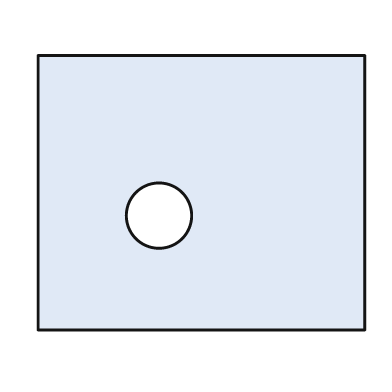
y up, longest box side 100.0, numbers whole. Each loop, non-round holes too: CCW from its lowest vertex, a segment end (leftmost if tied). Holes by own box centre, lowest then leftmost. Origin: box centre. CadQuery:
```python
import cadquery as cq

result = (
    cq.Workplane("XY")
    .moveTo(-50.0, -42.0)
    .lineTo(50.0, -42.0)
    .lineTo(50.0, 42.0)
    .lineTo(-50.0, 42.0)
    .close()
    .moveTo(-13.0, -7.0)
    .circle(10.0)
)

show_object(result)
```